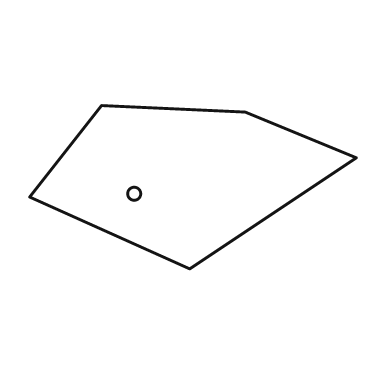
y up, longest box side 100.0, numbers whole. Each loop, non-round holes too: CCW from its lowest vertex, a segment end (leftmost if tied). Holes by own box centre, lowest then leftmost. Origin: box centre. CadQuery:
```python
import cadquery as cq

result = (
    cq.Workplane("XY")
    .moveTo(-1.0, -25.0)
    .lineTo(50.0, 9.0)
    .lineTo(16.0, 23.0)
    .lineTo(-28.0, 25.0)
    .lineTo(-50.0, -3.0)
    .close()
    .moveTo(-18.0, -2.0)
    .circle(2.0)
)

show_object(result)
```